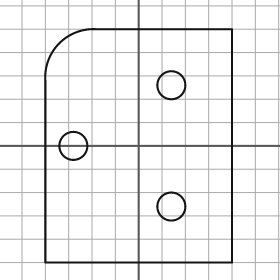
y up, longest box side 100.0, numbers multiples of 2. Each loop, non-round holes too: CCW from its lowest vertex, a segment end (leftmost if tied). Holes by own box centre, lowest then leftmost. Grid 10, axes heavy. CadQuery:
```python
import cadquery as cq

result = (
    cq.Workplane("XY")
    .moveTo(-40.0, -50.0)
    .lineTo(40.0, -50.0)
    .lineTo(40.0, 50.0)
    .lineTo(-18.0, 50.0)
    .threePointArc((-34.0, 44.0), (-40.0, 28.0))
    .close()
    .moveTo(14.0, -26.0)
    .circle(6.0)
    .moveTo(-28.0, 0.0)
    .circle(6.0)
    .moveTo(14.0, 26.0)
    .circle(6.0)
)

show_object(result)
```